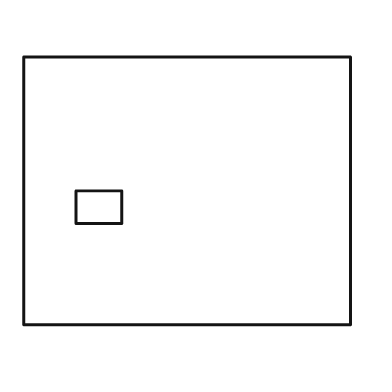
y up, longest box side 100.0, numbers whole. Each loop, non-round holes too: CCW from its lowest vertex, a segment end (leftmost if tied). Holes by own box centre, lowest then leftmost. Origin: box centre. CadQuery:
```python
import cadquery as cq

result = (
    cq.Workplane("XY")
    .moveTo(-50.0, -41.0)
    .lineTo(50.0, -41.0)
    .lineTo(50.0, 41.0)
    .lineTo(-50.0, 41.0)
    .close()
    .moveTo(-34.0, -10.0)
    .lineTo(-20.0, -10.0)
    .lineTo(-20.0, 0.0)
    .lineTo(-34.0, 0.0)
    .close()
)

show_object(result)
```